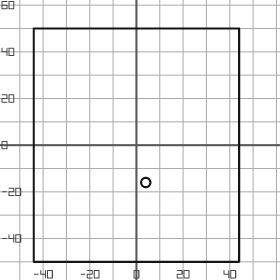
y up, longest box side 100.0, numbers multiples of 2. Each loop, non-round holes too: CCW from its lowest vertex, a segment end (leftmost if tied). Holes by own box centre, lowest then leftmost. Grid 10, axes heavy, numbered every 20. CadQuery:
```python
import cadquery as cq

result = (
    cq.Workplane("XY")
    .moveTo(-44.0, -50.0)
    .lineTo(44.0, -50.0)
    .lineTo(44.0, 50.0)
    .lineTo(-44.0, 50.0)
    .close()
    .moveTo(4.0, -16.0)
    .circle(2.0)
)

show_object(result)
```